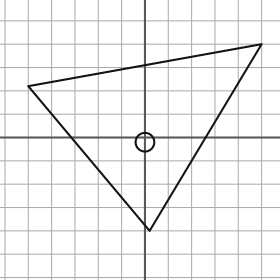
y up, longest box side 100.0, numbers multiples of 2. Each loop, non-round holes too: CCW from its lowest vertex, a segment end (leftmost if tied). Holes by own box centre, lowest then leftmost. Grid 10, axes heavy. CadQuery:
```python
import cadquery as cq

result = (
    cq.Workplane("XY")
    .moveTo(2.0, -40.0)
    .lineTo(50.0, 40.0)
    .lineTo(-50.0, 22.0)
    .close()
    .moveTo(0.0, -2.0)
    .circle(4.0)
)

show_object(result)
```